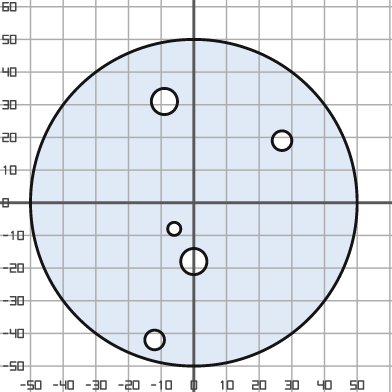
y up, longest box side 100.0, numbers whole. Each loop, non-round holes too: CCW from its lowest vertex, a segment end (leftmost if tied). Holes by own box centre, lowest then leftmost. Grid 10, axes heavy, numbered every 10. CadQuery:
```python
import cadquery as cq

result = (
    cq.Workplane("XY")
    .moveTo(0.0, 0.0)
    .circle(50.0)
    .moveTo(-12.0, -42.0)
    .circle(3.0)
    .moveTo(0.0, -18.0)
    .circle(4.0)
    .moveTo(-6.0, -8.0)
    .circle(2.0)
    .moveTo(27.0, 19.0)
    .circle(3.0)
    .moveTo(-9.0, 31.0)
    .circle(4.0)
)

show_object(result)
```